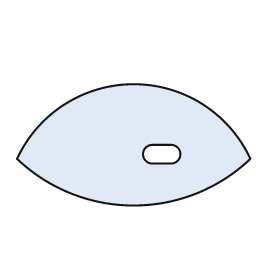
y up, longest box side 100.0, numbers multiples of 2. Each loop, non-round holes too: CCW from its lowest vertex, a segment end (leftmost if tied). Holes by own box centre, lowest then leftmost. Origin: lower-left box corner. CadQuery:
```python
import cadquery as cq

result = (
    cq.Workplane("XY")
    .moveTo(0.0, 20.0)
    .threePointArc((50.0, 0.0), (100.0, 20.0))
    .threePointArc((50.0, 52.0), (0.0, 20.0))
    .close()
    .moveTo(58.0, 18.0)
    .lineTo(66.0, 18.0)
    .threePointArc((70.0, 22.0), (66.0, 26.0))
    .lineTo(58.0, 26.0)
    .threePointArc((54.0, 22.0), (58.0, 18.0))
    .close()
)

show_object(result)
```